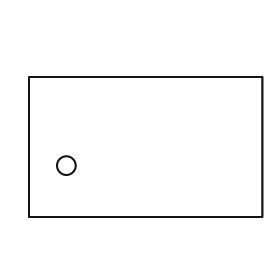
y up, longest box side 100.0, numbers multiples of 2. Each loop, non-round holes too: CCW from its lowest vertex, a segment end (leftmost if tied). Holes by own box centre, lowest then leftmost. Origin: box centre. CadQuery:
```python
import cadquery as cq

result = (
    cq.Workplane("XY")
    .moveTo(-50.0, -30.0)
    .lineTo(50.0, -30.0)
    .lineTo(50.0, 30.0)
    .lineTo(-50.0, 30.0)
    .close()
    .moveTo(-34.0, -8.0)
    .circle(4.0)
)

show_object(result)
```